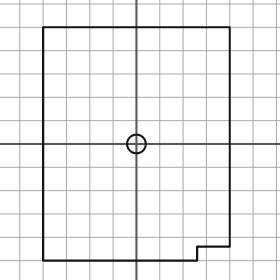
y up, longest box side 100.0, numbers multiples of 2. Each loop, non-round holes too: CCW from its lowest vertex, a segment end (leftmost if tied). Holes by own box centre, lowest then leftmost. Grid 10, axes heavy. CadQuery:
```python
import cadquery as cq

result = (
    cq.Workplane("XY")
    .moveTo(-40.0, -50.0)
    .lineTo(26.0, -50.0)
    .lineTo(26.0, -44.0)
    .lineTo(40.0, -44.0)
    .lineTo(40.0, 50.0)
    .lineTo(-40.0, 50.0)
    .close()
    .moveTo(0.0, 0.0)
    .circle(4.0)
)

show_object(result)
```